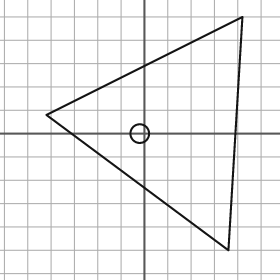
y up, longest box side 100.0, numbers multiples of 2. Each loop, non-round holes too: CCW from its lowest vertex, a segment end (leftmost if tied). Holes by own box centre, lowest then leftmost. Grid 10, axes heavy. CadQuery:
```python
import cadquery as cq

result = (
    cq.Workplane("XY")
    .moveTo(36.0, -50.0)
    .lineTo(42.0, 50.0)
    .lineTo(-42.0, 8.0)
    .close()
    .moveTo(-2.0, 0.0)
    .circle(4.0)
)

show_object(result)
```